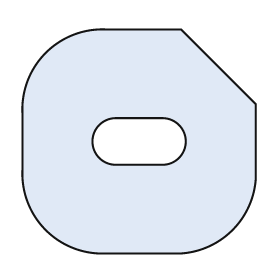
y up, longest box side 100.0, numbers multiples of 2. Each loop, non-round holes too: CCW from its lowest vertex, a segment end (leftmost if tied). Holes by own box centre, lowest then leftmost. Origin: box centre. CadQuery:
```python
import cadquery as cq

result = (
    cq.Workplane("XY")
    .moveTo(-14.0, -48.0)
    .lineTo(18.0, -48.0)
    .threePointArc((40.0, -38.0), (50.0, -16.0))
    .lineTo(50.0, 16.0)
    .lineTo(18.0, 48.0)
    .lineTo(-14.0, 48.0)
    .threePointArc((-40.0, 38.0), (-50.0, 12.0))
    .lineTo(-50.0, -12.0)
    .threePointArc((-40.0, -38.0), (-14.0, -48.0))
    .close()
    .moveTo(-10.0, -10.0)
    .lineTo(10.0, -10.0)
    .threePointArc((20.0, 0.0), (10.0, 10.0))
    .lineTo(-10.0, 10.0)
    .threePointArc((-20.0, 0.0), (-10.0, -10.0))
    .close()
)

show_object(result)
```